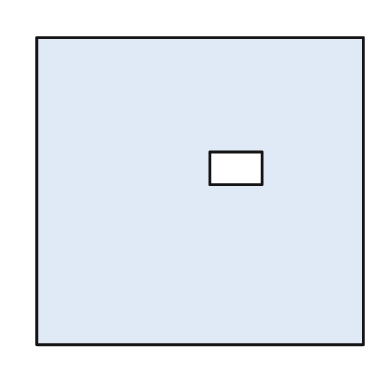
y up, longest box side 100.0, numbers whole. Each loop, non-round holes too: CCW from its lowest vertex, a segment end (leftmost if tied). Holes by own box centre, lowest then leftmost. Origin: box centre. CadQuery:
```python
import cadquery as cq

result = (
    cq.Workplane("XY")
    .moveTo(-50.0, -47.0)
    .lineTo(50.0, -47.0)
    .lineTo(50.0, 47.0)
    .lineTo(-50.0, 47.0)
    .close()
    .moveTo(3.0, 2.0)
    .lineTo(19.0, 2.0)
    .lineTo(19.0, 12.0)
    .lineTo(3.0, 12.0)
    .close()
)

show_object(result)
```